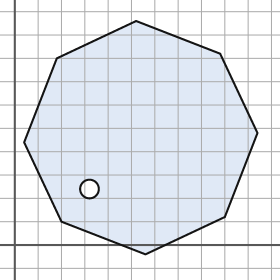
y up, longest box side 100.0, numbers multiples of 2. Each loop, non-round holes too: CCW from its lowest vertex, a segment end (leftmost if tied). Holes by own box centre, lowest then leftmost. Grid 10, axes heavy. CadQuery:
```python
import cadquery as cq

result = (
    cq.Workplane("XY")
    .moveTo(56.0, -4.0)
    .lineTo(90.0, 12.0)
    .lineTo(104.0, 48.0)
    .lineTo(88.0, 82.0)
    .lineTo(52.0, 96.0)
    .lineTo(18.0, 80.0)
    .lineTo(4.0, 44.0)
    .lineTo(20.0, 10.0)
    .close()
    .moveTo(32.0, 24.0)
    .circle(4.0)
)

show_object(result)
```